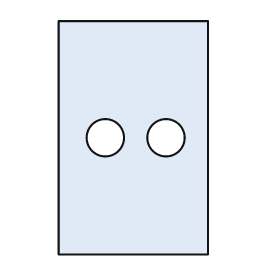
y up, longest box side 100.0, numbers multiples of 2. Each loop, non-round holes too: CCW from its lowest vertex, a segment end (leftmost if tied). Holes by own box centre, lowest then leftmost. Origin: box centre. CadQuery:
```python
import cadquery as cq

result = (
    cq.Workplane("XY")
    .moveTo(-32.0, -50.0)
    .lineTo(32.0, -50.0)
    .lineTo(32.0, 50.0)
    .lineTo(-32.0, 50.0)
    .close()
    .moveTo(-12.0, 0.0)
    .circle(8.0)
    .moveTo(14.0, 0.0)
    .circle(8.0)
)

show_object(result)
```